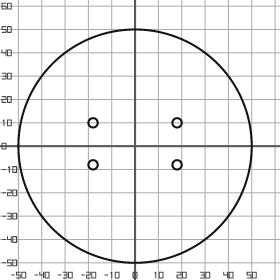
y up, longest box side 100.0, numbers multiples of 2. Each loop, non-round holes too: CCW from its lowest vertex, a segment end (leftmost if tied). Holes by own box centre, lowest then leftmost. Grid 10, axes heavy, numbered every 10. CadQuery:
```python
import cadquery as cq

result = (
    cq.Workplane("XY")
    .moveTo(0.0, 0.0)
    .circle(50.0)
    .moveTo(-18.0, -8.0)
    .circle(2.0)
    .moveTo(18.0, -8.0)
    .circle(2.0)
    .moveTo(-18.0, 10.0)
    .circle(2.0)
    .moveTo(18.0, 10.0)
    .circle(2.0)
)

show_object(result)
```